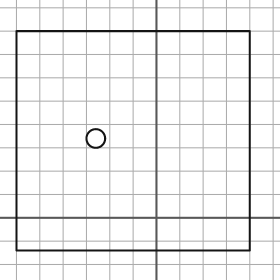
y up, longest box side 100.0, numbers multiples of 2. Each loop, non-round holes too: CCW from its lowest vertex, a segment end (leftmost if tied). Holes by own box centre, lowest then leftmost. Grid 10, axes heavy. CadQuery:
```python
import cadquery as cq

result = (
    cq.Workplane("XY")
    .moveTo(-60.0, -14.0)
    .lineTo(40.0, -14.0)
    .lineTo(40.0, 80.0)
    .lineTo(-60.0, 80.0)
    .close()
    .moveTo(-26.0, 34.0)
    .circle(4.0)
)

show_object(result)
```